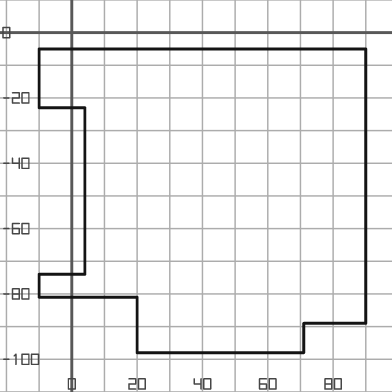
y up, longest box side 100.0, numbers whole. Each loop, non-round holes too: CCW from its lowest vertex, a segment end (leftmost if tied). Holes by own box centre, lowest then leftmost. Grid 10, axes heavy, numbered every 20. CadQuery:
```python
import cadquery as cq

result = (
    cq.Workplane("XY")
    .moveTo(20.0, -98.0)
    .lineTo(71.0, -98.0)
    .lineTo(71.0, -89.0)
    .lineTo(90.0, -89.0)
    .lineTo(90.0, -5.0)
    .lineTo(-10.0, -5.0)
    .lineTo(-10.0, -23.0)
    .lineTo(4.0, -23.0)
    .lineTo(4.0, -74.0)
    .lineTo(-10.0, -74.0)
    .lineTo(-10.0, -81.0)
    .lineTo(20.0, -81.0)
    .close()
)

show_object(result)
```